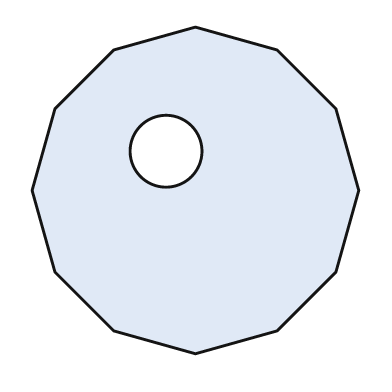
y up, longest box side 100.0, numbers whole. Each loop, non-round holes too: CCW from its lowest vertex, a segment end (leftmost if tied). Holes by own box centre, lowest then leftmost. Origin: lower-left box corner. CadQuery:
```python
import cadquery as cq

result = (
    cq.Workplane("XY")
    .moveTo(50.0, 0.0)
    .lineTo(75.0, 7.0)
    .lineTo(93.0, 25.0)
    .lineTo(100.0, 50.0)
    .lineTo(93.0, 75.0)
    .lineTo(75.0, 93.0)
    .lineTo(50.0, 100.0)
    .lineTo(25.0, 93.0)
    .lineTo(7.0, 75.0)
    .lineTo(0.0, 50.0)
    .lineTo(7.0, 25.0)
    .lineTo(25.0, 7.0)
    .close()
    .moveTo(41.0, 62.0)
    .circle(11.0)
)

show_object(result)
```